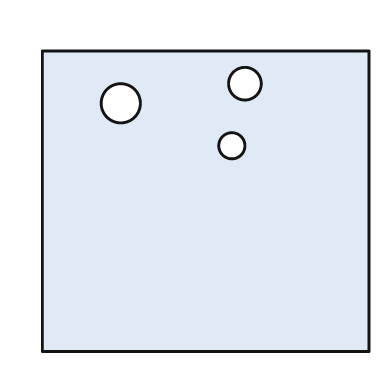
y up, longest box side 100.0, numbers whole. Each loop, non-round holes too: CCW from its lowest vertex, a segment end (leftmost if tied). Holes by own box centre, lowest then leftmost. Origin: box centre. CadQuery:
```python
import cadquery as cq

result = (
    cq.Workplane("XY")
    .moveTo(-50.0, -46.0)
    .lineTo(50.0, -46.0)
    .lineTo(50.0, 46.0)
    .lineTo(-50.0, 46.0)
    .close()
    .moveTo(8.0, 17.0)
    .circle(4.0)
    .moveTo(-26.0, 30.0)
    .circle(6.0)
    .moveTo(12.0, 36.0)
    .circle(5.0)
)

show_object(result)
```